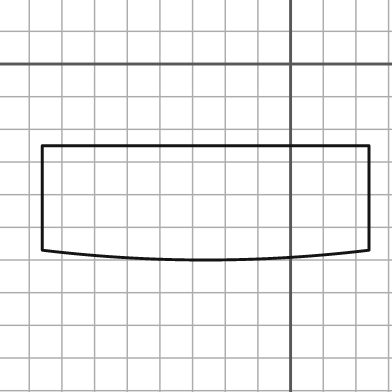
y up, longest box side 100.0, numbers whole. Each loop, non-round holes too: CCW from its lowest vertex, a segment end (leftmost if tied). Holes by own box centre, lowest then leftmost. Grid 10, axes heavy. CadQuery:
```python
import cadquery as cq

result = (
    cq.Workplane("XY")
    .moveTo(-76.0, -57.0)
    .threePointArc((-26.0, -60.0), (24.0, -57.0))
    .lineTo(24.0, -25.0)
    .lineTo(-76.0, -25.0)
    .close()
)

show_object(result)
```